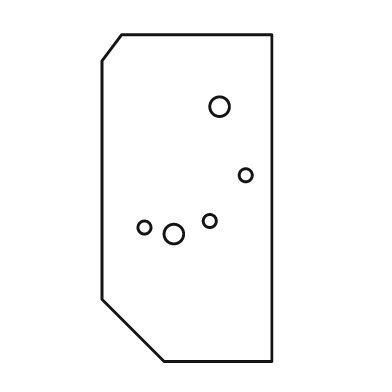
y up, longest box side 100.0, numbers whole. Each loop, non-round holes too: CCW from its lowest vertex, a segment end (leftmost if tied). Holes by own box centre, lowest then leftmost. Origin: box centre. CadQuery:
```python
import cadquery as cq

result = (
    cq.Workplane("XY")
    .moveTo(-7.0, -50.0)
    .lineTo(26.0, -50.0)
    .lineTo(26.0, 50.0)
    .lineTo(-20.0, 50.0)
    .lineTo(-26.0, 42.0)
    .lineTo(-26.0, -31.0)
    .close()
    .moveTo(-4.0, -11.0)
    .circle(3.0)
    .moveTo(-13.0, -9.0)
    .circle(2.0)
    .moveTo(7.0, -7.0)
    .circle(2.0)
    .moveTo(18.0, 7.0)
    .circle(2.0)
    .moveTo(10.0, 28.0)
    .circle(3.0)
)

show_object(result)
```